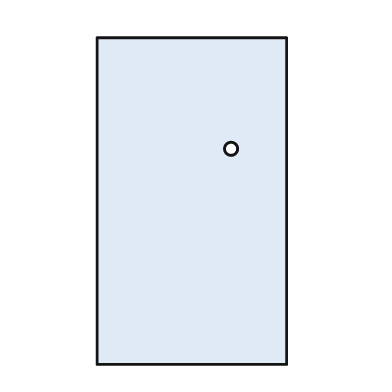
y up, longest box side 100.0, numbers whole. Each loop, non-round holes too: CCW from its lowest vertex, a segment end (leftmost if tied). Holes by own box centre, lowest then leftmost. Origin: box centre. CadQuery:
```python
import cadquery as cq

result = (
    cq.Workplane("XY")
    .moveTo(-29.0, -50.0)
    .lineTo(29.0, -50.0)
    .lineTo(29.0, 50.0)
    .lineTo(-29.0, 50.0)
    .close()
    .moveTo(12.0, 16.0)
    .circle(2.0)
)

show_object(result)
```